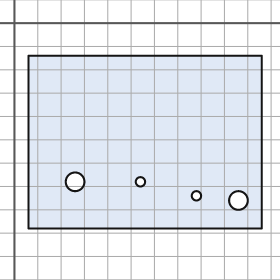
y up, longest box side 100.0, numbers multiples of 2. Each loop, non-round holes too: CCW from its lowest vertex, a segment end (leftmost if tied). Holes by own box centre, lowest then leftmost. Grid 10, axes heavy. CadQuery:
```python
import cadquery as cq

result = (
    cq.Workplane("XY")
    .moveTo(6.0, -88.0)
    .lineTo(106.0, -88.0)
    .lineTo(106.0, -14.0)
    .lineTo(6.0, -14.0)
    .close()
    .moveTo(96.0, -76.0)
    .circle(4.0)
    .moveTo(78.0, -74.0)
    .circle(2.0)
    .moveTo(26.0, -68.0)
    .circle(4.0)
    .moveTo(54.0, -68.0)
    .circle(2.0)
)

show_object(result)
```